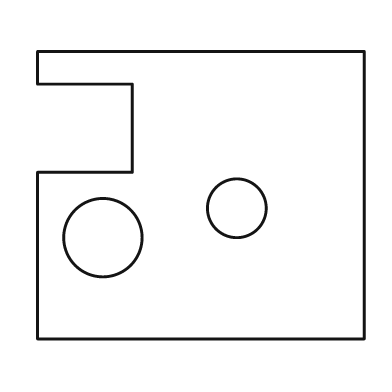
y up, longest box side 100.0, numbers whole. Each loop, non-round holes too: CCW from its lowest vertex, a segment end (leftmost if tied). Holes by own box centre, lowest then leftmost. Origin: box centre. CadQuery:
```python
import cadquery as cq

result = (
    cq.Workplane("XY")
    .moveTo(-50.0, -44.0)
    .lineTo(50.0, -44.0)
    .lineTo(50.0, 44.0)
    .lineTo(-50.0, 44.0)
    .lineTo(-50.0, 34.0)
    .lineTo(-21.0, 34.0)
    .lineTo(-21.0, 7.0)
    .lineTo(-50.0, 7.0)
    .close()
    .moveTo(-30.0, -13.0)
    .circle(12.0)
    .moveTo(11.0, -4.0)
    .circle(9.0)
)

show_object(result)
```